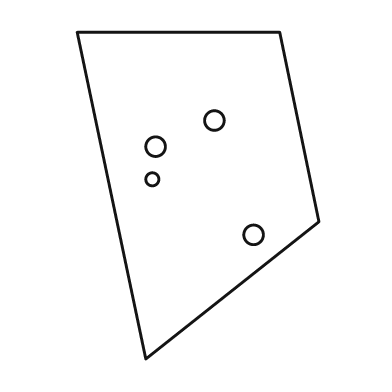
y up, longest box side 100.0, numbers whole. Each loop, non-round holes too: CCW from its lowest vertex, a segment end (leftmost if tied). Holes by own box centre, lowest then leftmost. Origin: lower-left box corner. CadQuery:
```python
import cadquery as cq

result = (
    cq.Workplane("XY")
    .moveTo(21.0, 0.0)
    .lineTo(74.0, 42.0)
    .lineTo(62.0, 100.0)
    .lineTo(0.0, 100.0)
    .close()
    .moveTo(54.0, 38.0)
    .circle(3.0)
    .moveTo(23.0, 55.0)
    .circle(2.0)
    .moveTo(24.0, 65.0)
    .circle(3.0)
    .moveTo(42.0, 73.0)
    .circle(3.0)
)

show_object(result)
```